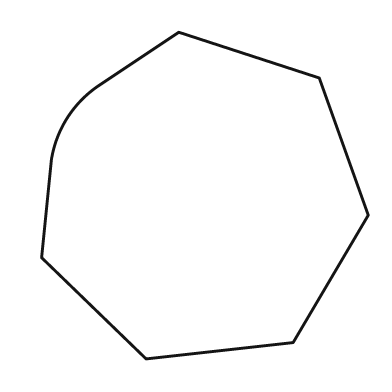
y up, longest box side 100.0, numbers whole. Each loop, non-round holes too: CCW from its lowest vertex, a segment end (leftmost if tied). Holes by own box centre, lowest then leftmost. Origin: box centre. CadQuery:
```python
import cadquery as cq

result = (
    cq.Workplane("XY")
    .moveTo(-18.0, -50.0)
    .lineTo(27.0, -45.0)
    .lineTo(50.0, -6.0)
    .lineTo(35.0, 36.0)
    .lineTo(-8.0, 50.0)
    .lineTo(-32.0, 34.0)
    .threePointArc((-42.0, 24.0), (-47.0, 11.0))
    .lineTo(-50.0, -19.0)
    .close()
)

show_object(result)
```